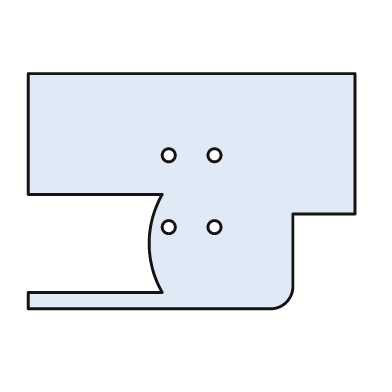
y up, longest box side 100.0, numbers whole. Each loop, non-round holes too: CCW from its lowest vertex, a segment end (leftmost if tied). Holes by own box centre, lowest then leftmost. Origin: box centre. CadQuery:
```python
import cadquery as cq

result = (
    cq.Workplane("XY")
    .moveTo(-50.0, -36.0)
    .lineTo(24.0, -36.0)
    .threePointArc((29.0, -34.0), (31.0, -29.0))
    .lineTo(31.0, -7.0)
    .lineTo(50.0, -7.0)
    .lineTo(50.0, 36.0)
    .lineTo(-50.0, 36.0)
    .lineTo(-50.0, -1.0)
    .lineTo(-9.0, -1.0)
    .threePointArc((-13.0, -16.0), (-9.0, -31.0))
    .lineTo(-50.0, -31.0)
    .close()
    .moveTo(-7.0, -11.0)
    .circle(2.0)
    .moveTo(7.0, -11.0)
    .circle(2.0)
    .moveTo(-7.0, 11.0)
    .circle(2.0)
    .moveTo(7.0, 11.0)
    .circle(2.0)
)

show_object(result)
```